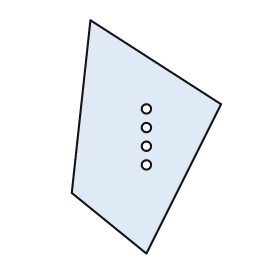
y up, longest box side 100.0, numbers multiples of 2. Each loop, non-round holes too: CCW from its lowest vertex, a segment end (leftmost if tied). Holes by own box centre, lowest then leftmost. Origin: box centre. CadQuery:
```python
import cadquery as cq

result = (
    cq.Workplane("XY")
    .moveTo(0.0, -50.0)
    .lineTo(32.0, 14.0)
    .lineTo(-24.0, 50.0)
    .lineTo(-32.0, -24.0)
    .close()
    .moveTo(0.0, -12.0)
    .circle(2.0)
    .moveTo(0.0, -4.0)
    .circle(2.0)
    .moveTo(0.0, 4.0)
    .circle(2.0)
    .moveTo(0.0, 12.0)
    .circle(2.0)
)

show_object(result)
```